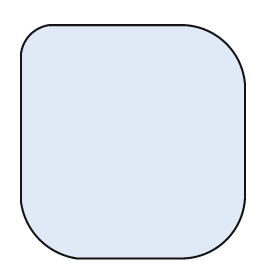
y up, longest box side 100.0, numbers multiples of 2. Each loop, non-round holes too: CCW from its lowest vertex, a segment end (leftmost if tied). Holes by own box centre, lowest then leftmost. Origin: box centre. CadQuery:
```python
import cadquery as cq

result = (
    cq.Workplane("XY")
    .moveTo(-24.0, -50.0)
    .lineTo(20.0, -50.0)
    .threePointArc((40.0, -42.0), (48.0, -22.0))
    .lineTo(48.0, 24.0)
    .threePointArc((40.0, 42.0), (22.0, 50.0))
    .lineTo(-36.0, 50.0)
    .threePointArc((-44.0, 46.0), (-48.0, 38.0))
    .lineTo(-48.0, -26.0)
    .threePointArc((-40.0, -42.0), (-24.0, -50.0))
    .close()
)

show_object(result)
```